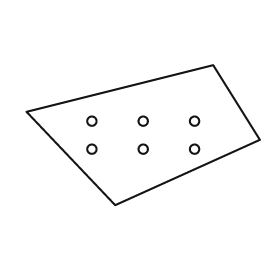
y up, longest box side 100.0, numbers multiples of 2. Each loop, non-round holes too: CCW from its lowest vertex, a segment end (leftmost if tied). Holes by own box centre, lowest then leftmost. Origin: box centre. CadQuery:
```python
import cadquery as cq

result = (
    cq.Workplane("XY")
    .moveTo(-12.0, -30.0)
    .lineTo(50.0, -2.0)
    .lineTo(30.0, 30.0)
    .lineTo(-50.0, 10.0)
    .close()
    .moveTo(-22.0, -6.0)
    .circle(2.0)
    .moveTo(0.0, -6.0)
    .circle(2.0)
    .moveTo(22.0, -6.0)
    .circle(2.0)
    .moveTo(-22.0, 6.0)
    .circle(2.0)
    .moveTo(0.0, 6.0)
    .circle(2.0)
    .moveTo(22.0, 6.0)
    .circle(2.0)
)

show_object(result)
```